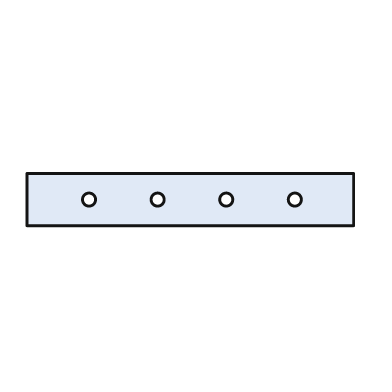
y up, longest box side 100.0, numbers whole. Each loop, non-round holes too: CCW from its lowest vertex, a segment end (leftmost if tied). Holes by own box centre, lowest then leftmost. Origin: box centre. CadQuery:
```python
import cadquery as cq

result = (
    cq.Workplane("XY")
    .moveTo(-50.0, -8.0)
    .lineTo(50.0, -8.0)
    .lineTo(50.0, 8.0)
    .lineTo(-50.0, 8.0)
    .close()
    .moveTo(-31.0, 0.0)
    .circle(2.0)
    .moveTo(-10.0, 0.0)
    .circle(2.0)
    .moveTo(11.0, 0.0)
    .circle(2.0)
    .moveTo(32.0, 0.0)
    .circle(2.0)
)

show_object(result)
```